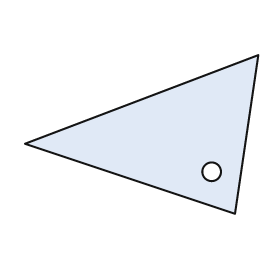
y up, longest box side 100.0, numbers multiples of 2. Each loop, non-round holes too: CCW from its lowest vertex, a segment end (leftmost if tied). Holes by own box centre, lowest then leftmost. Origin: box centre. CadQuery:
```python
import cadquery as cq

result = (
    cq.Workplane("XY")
    .moveTo(40.0, -34.0)
    .lineTo(50.0, 34.0)
    .lineTo(-50.0, -4.0)
    .close()
    .moveTo(30.0, -16.0)
    .circle(4.0)
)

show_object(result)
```